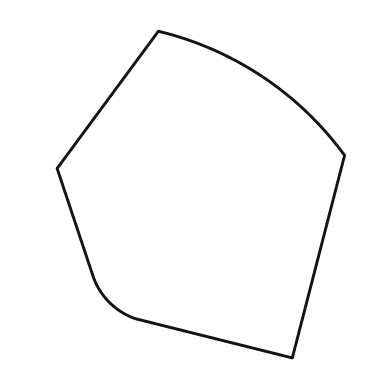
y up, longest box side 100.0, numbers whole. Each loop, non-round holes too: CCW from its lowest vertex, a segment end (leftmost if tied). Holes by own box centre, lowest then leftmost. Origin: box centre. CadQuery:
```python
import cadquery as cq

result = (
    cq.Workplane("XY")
    .moveTo(28.0, -50.0)
    .lineTo(44.0, 12.0)
    .threePointArc((19.0, 36.0), (-13.0, 50.0))
    .lineTo(-44.0, 8.0)
    .lineTo(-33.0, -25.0)
    .threePointArc((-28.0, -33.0), (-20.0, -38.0))
    .close()
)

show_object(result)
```